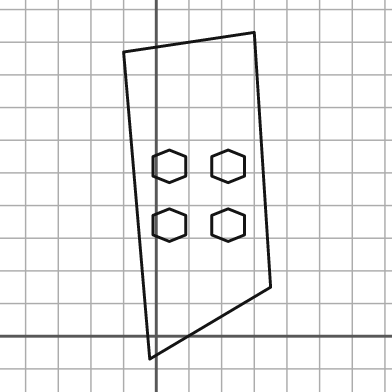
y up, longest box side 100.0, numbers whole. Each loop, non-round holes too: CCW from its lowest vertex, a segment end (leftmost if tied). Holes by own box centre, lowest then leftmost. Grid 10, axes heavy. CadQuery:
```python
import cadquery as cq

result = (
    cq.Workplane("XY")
    .moveTo(-2.0, -7.0)
    .lineTo(35.0, 15.0)
    .lineTo(30.0, 93.0)
    .lineTo(-10.0, 87.0)
    .close()
    .moveTo(4.0, 29.0)
    .lineTo(9.0, 31.0)
    .lineTo(9.0, 37.0)
    .lineTo(4.0, 39.0)
    .lineTo(-1.0, 37.0)
    .lineTo(-1.0, 31.0)
    .close()
    .moveTo(22.0, 29.0)
    .lineTo(27.0, 31.0)
    .lineTo(27.0, 37.0)
    .lineTo(22.0, 39.0)
    .lineTo(17.0, 37.0)
    .lineTo(17.0, 31.0)
    .close()
    .moveTo(4.0, 47.0)
    .lineTo(9.0, 49.0)
    .lineTo(9.0, 55.0)
    .lineTo(4.0, 57.0)
    .lineTo(-1.0, 55.0)
    .lineTo(-1.0, 49.0)
    .close()
    .moveTo(22.0, 47.0)
    .lineTo(27.0, 49.0)
    .lineTo(27.0, 55.0)
    .lineTo(22.0, 57.0)
    .lineTo(17.0, 55.0)
    .lineTo(17.0, 49.0)
    .close()
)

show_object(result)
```